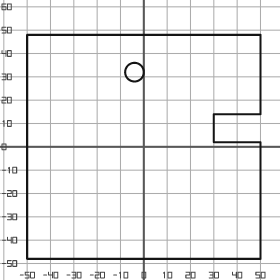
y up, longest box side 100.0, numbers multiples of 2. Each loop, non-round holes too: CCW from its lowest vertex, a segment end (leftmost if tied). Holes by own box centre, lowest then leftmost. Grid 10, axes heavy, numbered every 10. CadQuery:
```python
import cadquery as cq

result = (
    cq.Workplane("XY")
    .moveTo(-50.0, -48.0)
    .lineTo(50.0, -48.0)
    .lineTo(50.0, 2.0)
    .lineTo(30.0, 2.0)
    .lineTo(30.0, 14.0)
    .lineTo(50.0, 14.0)
    .lineTo(50.0, 48.0)
    .lineTo(-50.0, 48.0)
    .close()
    .moveTo(-4.0, 32.0)
    .circle(4.0)
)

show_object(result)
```